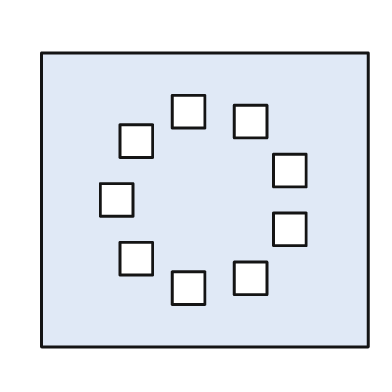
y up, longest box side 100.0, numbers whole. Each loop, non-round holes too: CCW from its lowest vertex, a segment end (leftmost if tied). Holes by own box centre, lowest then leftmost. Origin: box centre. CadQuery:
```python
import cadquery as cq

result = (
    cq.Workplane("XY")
    .moveTo(-50.0, -45.0)
    .lineTo(50.0, -45.0)
    .lineTo(50.0, 45.0)
    .lineTo(-50.0, 45.0)
    .close()
    .moveTo(-10.0, -32.0)
    .lineTo(0.0, -32.0)
    .lineTo(0.0, -22.0)
    .lineTo(-10.0, -22.0)
    .close()
    .moveTo(9.0, -29.0)
    .lineTo(19.0, -29.0)
    .lineTo(19.0, -19.0)
    .lineTo(9.0, -19.0)
    .close()
    .moveTo(-26.0, -23.0)
    .lineTo(-16.0, -23.0)
    .lineTo(-16.0, -13.0)
    .lineTo(-26.0, -13.0)
    .close()
    .moveTo(21.0, -14.0)
    .lineTo(31.0, -14.0)
    .lineTo(31.0, -4.0)
    .lineTo(21.0, -4.0)
    .close()
    .moveTo(-32.0, -5.0)
    .lineTo(-22.0, -5.0)
    .lineTo(-22.0, 5.0)
    .lineTo(-32.0, 5.0)
    .close()
    .moveTo(21.0, 4.0)
    .lineTo(31.0, 4.0)
    .lineTo(31.0, 14.0)
    .lineTo(21.0, 14.0)
    .close()
    .moveTo(-26.0, 13.0)
    .lineTo(-16.0, 13.0)
    .lineTo(-16.0, 23.0)
    .lineTo(-26.0, 23.0)
    .close()
    .moveTo(9.0, 19.0)
    .lineTo(19.0, 19.0)
    .lineTo(19.0, 29.0)
    .lineTo(9.0, 29.0)
    .close()
    .moveTo(-10.0, 22.0)
    .lineTo(0.0, 22.0)
    .lineTo(0.0, 32.0)
    .lineTo(-10.0, 32.0)
    .close()
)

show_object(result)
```